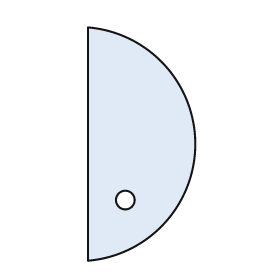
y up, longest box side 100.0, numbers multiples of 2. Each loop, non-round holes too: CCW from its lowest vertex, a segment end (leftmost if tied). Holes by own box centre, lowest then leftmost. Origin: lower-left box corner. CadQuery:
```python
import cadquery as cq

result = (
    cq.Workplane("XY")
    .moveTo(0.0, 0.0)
    .threePointArc((46.0, 50.0), (0.0, 100.0))
    .close()
    .moveTo(16.0, 26.0)
    .circle(4.0)
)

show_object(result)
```